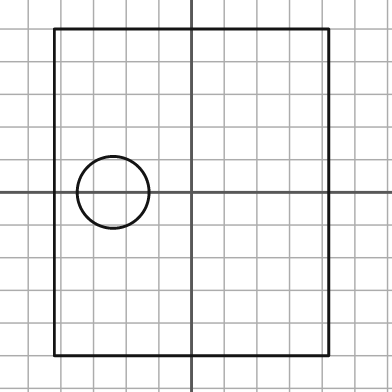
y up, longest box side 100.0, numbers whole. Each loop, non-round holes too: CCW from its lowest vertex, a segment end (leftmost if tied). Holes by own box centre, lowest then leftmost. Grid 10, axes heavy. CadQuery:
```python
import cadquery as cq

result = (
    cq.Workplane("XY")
    .moveTo(-42.0, -50.0)
    .lineTo(42.0, -50.0)
    .lineTo(42.0, 50.0)
    .lineTo(-42.0, 50.0)
    .close()
    .moveTo(-24.0, 0.0)
    .circle(11.0)
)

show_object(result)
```